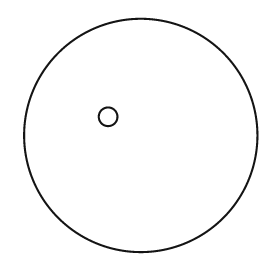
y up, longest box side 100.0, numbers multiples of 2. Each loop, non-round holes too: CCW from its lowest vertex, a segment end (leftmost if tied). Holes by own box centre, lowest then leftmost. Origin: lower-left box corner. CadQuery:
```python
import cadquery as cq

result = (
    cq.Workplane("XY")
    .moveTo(50.0, 50.0)
    .circle(50.0)
    .moveTo(36.0, 58.0)
    .circle(4.0)
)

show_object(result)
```